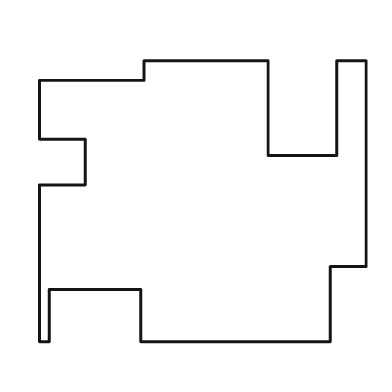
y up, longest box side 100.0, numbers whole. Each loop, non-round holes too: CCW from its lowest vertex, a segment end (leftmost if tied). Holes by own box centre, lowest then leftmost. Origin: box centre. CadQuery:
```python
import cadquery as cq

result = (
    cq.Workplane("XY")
    .moveTo(-50.0, -43.0)
    .lineTo(-47.0, -43.0)
    .lineTo(-47.0, -27.0)
    .lineTo(-19.0, -27.0)
    .lineTo(-19.0, -43.0)
    .lineTo(39.0, -43.0)
    .lineTo(39.0, -20.0)
    .lineTo(50.0, -20.0)
    .lineTo(50.0, 43.0)
    .lineTo(41.0, 43.0)
    .lineTo(41.0, 14.0)
    .lineTo(20.0, 14.0)
    .lineTo(20.0, 43.0)
    .lineTo(-18.0, 43.0)
    .lineTo(-18.0, 37.0)
    .lineTo(-50.0, 37.0)
    .lineTo(-50.0, 19.0)
    .lineTo(-36.0, 19.0)
    .lineTo(-36.0, 5.0)
    .lineTo(-50.0, 5.0)
    .close()
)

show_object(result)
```